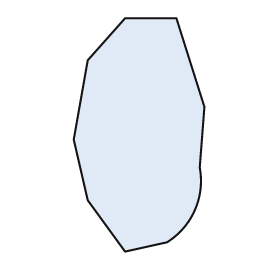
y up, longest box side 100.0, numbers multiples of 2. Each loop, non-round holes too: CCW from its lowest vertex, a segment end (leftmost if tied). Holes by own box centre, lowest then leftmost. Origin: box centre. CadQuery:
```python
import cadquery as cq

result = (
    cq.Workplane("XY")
    .moveTo(-6.0, -50.0)
    .lineTo(12.0, -46.0)
    .threePointArc((24.0, -32.0), (26.0, -14.0))
    .lineTo(28.0, 12.0)
    .lineTo(16.0, 50.0)
    .lineTo(-6.0, 50.0)
    .lineTo(-22.0, 32.0)
    .lineTo(-28.0, -2.0)
    .lineTo(-22.0, -28.0)
    .close()
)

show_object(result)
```